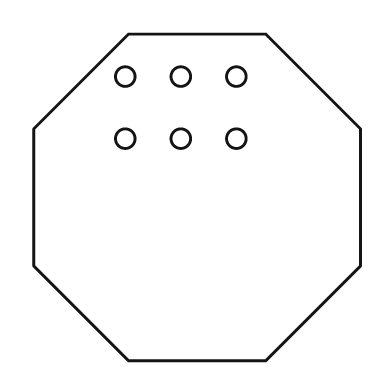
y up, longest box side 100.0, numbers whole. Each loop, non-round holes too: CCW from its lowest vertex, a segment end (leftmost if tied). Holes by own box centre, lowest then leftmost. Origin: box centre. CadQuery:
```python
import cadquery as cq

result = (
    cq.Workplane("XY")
    .moveTo(-21.0, -50.0)
    .lineTo(21.0, -50.0)
    .lineTo(50.0, -21.0)
    .lineTo(50.0, 21.0)
    .lineTo(21.0, 50.0)
    .lineTo(-21.0, 50.0)
    .lineTo(-50.0, 21.0)
    .lineTo(-50.0, -21.0)
    .close()
    .moveTo(-22.0, 18.0)
    .circle(3.0)
    .moveTo(-5.0, 18.0)
    .circle(3.0)
    .moveTo(12.0, 18.0)
    .circle(3.0)
    .moveTo(-22.0, 37.0)
    .circle(3.0)
    .moveTo(-5.0, 37.0)
    .circle(3.0)
    .moveTo(12.0, 37.0)
    .circle(3.0)
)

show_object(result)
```